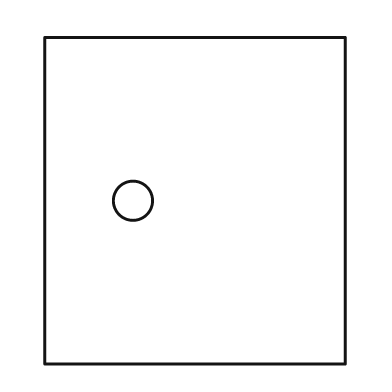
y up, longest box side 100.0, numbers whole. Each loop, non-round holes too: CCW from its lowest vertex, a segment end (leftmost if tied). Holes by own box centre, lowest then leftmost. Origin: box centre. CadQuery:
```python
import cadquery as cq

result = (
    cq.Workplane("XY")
    .moveTo(-46.0, -50.0)
    .lineTo(46.0, -50.0)
    .lineTo(46.0, 50.0)
    .lineTo(-46.0, 50.0)
    .close()
    .moveTo(-19.0, 0.0)
    .circle(6.0)
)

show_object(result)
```